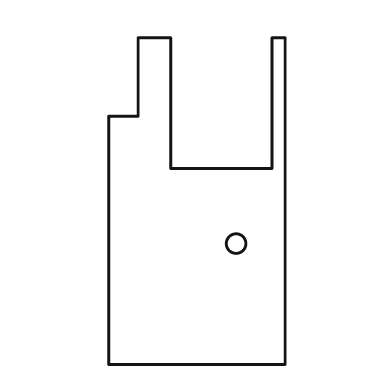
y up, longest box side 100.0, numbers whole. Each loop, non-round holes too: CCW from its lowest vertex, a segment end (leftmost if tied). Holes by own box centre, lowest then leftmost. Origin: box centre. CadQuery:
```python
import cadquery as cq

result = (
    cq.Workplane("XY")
    .moveTo(-27.0, -50.0)
    .lineTo(27.0, -50.0)
    .lineTo(27.0, 50.0)
    .lineTo(23.0, 50.0)
    .lineTo(23.0, 10.0)
    .lineTo(-8.0, 10.0)
    .lineTo(-8.0, 50.0)
    .lineTo(-18.0, 50.0)
    .lineTo(-18.0, 26.0)
    .lineTo(-27.0, 26.0)
    .close()
    .moveTo(12.0, -13.0)
    .circle(3.0)
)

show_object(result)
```